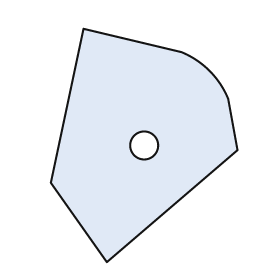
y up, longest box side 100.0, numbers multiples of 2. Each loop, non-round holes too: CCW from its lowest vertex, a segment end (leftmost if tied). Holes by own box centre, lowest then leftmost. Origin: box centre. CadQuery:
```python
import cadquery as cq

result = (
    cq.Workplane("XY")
    .moveTo(-16.0, -50.0)
    .lineTo(40.0, -2.0)
    .lineTo(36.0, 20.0)
    .threePointArc((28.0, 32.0), (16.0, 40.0))
    .lineTo(-26.0, 50.0)
    .lineTo(-40.0, -16.0)
    .close()
    .moveTo(0.0, 0.0)
    .circle(6.0)
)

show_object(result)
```